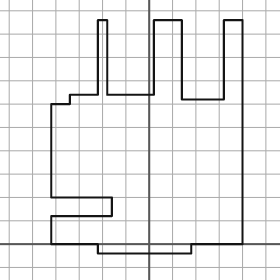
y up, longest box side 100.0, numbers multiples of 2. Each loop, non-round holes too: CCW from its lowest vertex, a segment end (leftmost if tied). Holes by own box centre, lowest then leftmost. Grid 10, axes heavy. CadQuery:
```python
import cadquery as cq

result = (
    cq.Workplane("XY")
    .moveTo(-22.0, -4.0)
    .lineTo(18.0, -4.0)
    .lineTo(18.0, 0.0)
    .lineTo(40.0, 0.0)
    .lineTo(40.0, 96.0)
    .lineTo(32.0, 96.0)
    .lineTo(32.0, 62.0)
    .lineTo(14.0, 62.0)
    .lineTo(14.0, 96.0)
    .lineTo(2.0, 96.0)
    .lineTo(2.0, 64.0)
    .lineTo(-18.0, 64.0)
    .lineTo(-18.0, 96.0)
    .lineTo(-22.0, 96.0)
    .lineTo(-22.0, 64.0)
    .lineTo(-34.0, 64.0)
    .lineTo(-34.0, 60.0)
    .lineTo(-42.0, 60.0)
    .lineTo(-42.0, 20.0)
    .lineTo(-16.0, 20.0)
    .lineTo(-16.0, 12.0)
    .lineTo(-42.0, 12.0)
    .lineTo(-42.0, 0.0)
    .lineTo(-22.0, 0.0)
    .close()
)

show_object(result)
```